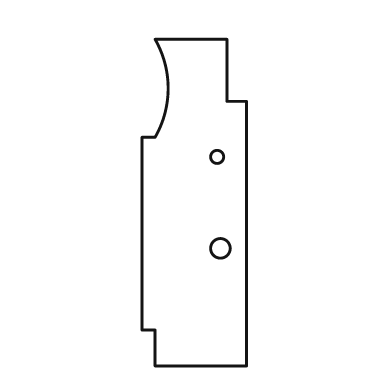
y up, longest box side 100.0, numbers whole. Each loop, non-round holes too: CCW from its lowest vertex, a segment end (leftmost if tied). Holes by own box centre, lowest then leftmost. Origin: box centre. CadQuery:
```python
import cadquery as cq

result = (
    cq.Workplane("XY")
    .moveTo(-12.0, -50.0)
    .lineTo(16.0, -50.0)
    .lineTo(16.0, 31.0)
    .lineTo(10.0, 31.0)
    .lineTo(10.0, 50.0)
    .lineTo(-12.0, 50.0)
    .threePointArc((-8.0, 35.0), (-12.0, 20.0))
    .lineTo(-16.0, 20.0)
    .lineTo(-16.0, -39.0)
    .lineTo(-12.0, -39.0)
    .close()
    .moveTo(8.0, -14.0)
    .circle(3.0)
    .moveTo(7.0, 14.0)
    .circle(2.0)
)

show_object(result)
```